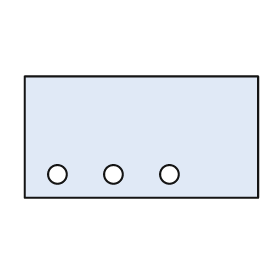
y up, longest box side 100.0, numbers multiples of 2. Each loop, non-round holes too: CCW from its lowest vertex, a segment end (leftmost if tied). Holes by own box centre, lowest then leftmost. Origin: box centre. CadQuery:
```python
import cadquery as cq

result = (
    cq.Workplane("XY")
    .moveTo(-50.0, -26.0)
    .lineTo(50.0, -26.0)
    .lineTo(50.0, 26.0)
    .lineTo(-50.0, 26.0)
    .close()
    .moveTo(-36.0, -16.0)
    .circle(4.0)
    .moveTo(-12.0, -16.0)
    .circle(4.0)
    .moveTo(12.0, -16.0)
    .circle(4.0)
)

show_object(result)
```